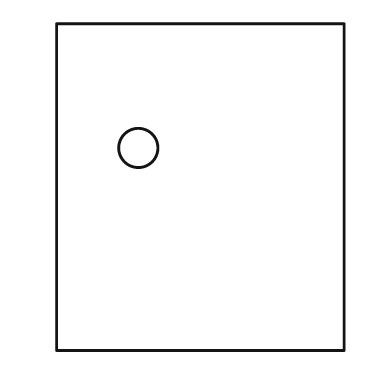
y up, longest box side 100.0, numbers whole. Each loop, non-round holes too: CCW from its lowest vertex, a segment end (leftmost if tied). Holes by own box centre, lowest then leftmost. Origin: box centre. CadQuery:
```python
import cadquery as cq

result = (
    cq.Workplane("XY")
    .moveTo(-44.0, -50.0)
    .lineTo(44.0, -50.0)
    .lineTo(44.0, 50.0)
    .lineTo(-44.0, 50.0)
    .close()
    .moveTo(-19.0, 12.0)
    .circle(6.0)
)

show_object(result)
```